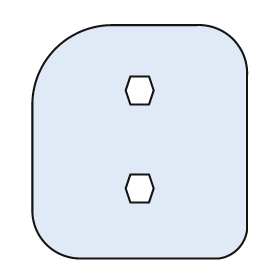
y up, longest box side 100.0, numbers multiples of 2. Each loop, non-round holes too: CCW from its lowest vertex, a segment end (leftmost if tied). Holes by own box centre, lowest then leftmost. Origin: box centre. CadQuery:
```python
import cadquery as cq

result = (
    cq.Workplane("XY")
    .moveTo(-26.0, -50.0)
    .lineTo(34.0, -50.0)
    .threePointArc((42.0, -46.0), (46.0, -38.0))
    .lineTo(46.0, 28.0)
    .threePointArc((40.0, 44.0), (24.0, 50.0))
    .lineTo(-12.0, 50.0)
    .threePointArc((-36.0, 40.0), (-46.0, 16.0))
    .lineTo(-46.0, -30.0)
    .threePointArc((-40.0, -44.0), (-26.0, -50.0))
    .close()
    .moveTo(-4.0, -26.0)
    .lineTo(4.0, -26.0)
    .lineTo(6.0, -20.0)
    .lineTo(4.0, -14.0)
    .lineTo(-4.0, -14.0)
    .lineTo(-6.0, -20.0)
    .close()
    .moveTo(-4.0, 16.0)
    .lineTo(4.0, 16.0)
    .lineTo(6.0, 22.0)
    .lineTo(4.0, 28.0)
    .lineTo(-4.0, 28.0)
    .lineTo(-6.0, 22.0)
    .close()
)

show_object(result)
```